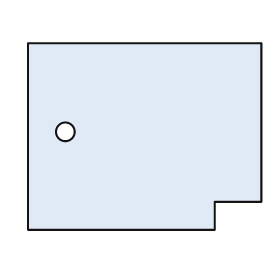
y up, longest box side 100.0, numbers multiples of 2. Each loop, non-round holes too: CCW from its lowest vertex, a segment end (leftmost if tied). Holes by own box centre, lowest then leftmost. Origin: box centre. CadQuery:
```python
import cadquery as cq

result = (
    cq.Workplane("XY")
    .moveTo(-50.0, -40.0)
    .lineTo(30.0, -40.0)
    .lineTo(30.0, -28.0)
    .lineTo(50.0, -28.0)
    .lineTo(50.0, 40.0)
    .lineTo(-50.0, 40.0)
    .close()
    .moveTo(-34.0, 2.0)
    .circle(4.0)
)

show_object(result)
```